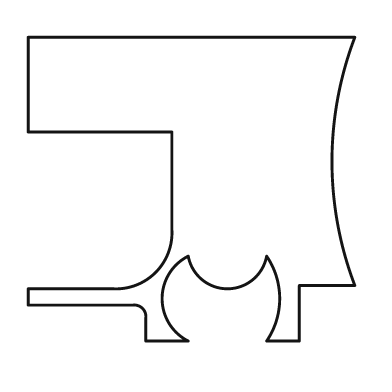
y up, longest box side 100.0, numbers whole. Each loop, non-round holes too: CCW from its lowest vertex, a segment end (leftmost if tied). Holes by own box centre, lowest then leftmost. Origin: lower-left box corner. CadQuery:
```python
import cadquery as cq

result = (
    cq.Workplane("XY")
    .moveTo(36.0, 0.0)
    .lineTo(49.0, 0.0)
    .threePointArc((41.0, 13.0), (49.0, 26.0))
    .threePointArc((61.0, 16.0), (73.0, 26.0))
    .threePointArc((77.0, 13.0), (73.0, 0.0))
    .lineTo(83.0, 0.0)
    .lineTo(83.0, 17.0)
    .lineTo(100.0, 17.0)
    .threePointArc((93.0, 55.0), (100.0, 93.0))
    .lineTo(0.0, 93.0)
    .lineTo(0.0, 64.0)
    .lineTo(44.0, 64.0)
    .lineTo(44.0, 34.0)
    .threePointArc((39.0, 21.0), (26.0, 16.0))
    .lineTo(0.0, 16.0)
    .lineTo(0.0, 11.0)
    .lineTo(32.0, 11.0)
    .threePointArc((35.0, 10.0), (36.0, 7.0))
    .close()
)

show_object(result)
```